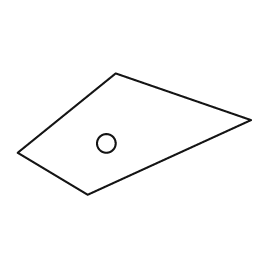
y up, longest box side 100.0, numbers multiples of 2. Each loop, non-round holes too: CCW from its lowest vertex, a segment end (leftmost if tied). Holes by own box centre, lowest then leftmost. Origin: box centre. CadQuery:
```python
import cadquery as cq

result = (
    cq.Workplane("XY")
    .moveTo(-20.0, -26.0)
    .lineTo(50.0, 6.0)
    .lineTo(-8.0, 26.0)
    .lineTo(-50.0, -8.0)
    .close()
    .moveTo(-12.0, -4.0)
    .circle(4.0)
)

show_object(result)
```